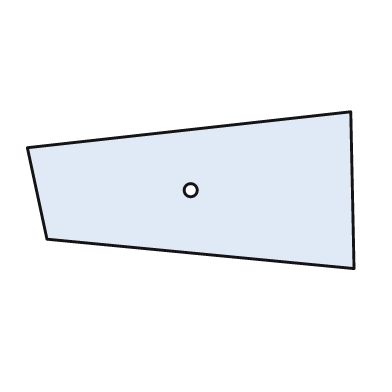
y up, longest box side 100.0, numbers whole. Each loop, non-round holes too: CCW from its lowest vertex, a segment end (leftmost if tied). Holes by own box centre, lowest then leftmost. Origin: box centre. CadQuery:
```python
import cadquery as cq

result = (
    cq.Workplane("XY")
    .moveTo(50.0, -24.0)
    .lineTo(49.0, 24.0)
    .lineTo(-50.0, 13.0)
    .lineTo(-44.0, -15.0)
    .close()
    .moveTo(0.0, 0.0)
    .circle(2.0)
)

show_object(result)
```